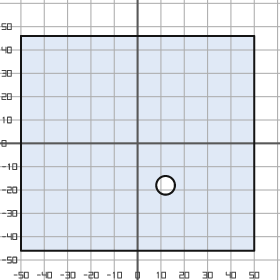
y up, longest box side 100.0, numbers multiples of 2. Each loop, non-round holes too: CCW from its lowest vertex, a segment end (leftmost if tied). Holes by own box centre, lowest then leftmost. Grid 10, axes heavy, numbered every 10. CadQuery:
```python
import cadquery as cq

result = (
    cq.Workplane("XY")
    .moveTo(-50.0, -46.0)
    .lineTo(50.0, -46.0)
    .lineTo(50.0, 46.0)
    .lineTo(-50.0, 46.0)
    .close()
    .moveTo(12.0, -18.0)
    .circle(4.0)
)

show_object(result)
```